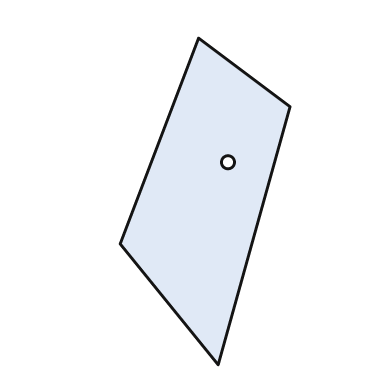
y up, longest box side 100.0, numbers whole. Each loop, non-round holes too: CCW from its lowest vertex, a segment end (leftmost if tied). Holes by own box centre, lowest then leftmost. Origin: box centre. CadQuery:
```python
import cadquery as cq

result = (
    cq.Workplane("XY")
    .moveTo(4.0, -50.0)
    .lineTo(26.0, 29.0)
    .lineTo(-2.0, 50.0)
    .lineTo(-26.0, -13.0)
    .close()
    .moveTo(7.0, 12.0)
    .circle(2.0)
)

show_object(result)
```